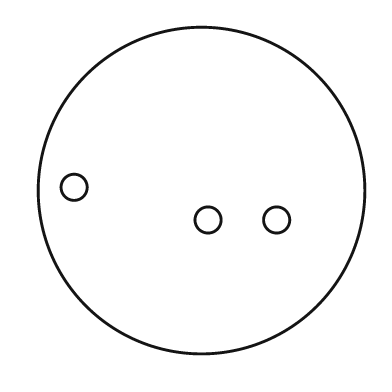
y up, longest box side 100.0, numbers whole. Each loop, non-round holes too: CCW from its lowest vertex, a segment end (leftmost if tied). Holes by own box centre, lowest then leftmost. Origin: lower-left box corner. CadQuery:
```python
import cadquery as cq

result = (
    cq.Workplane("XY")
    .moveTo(50.0, 50.0)
    .circle(50.0)
    .moveTo(52.0, 41.0)
    .circle(4.0)
    .moveTo(73.0, 41.0)
    .circle(4.0)
    .moveTo(11.0, 51.0)
    .circle(4.0)
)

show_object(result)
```